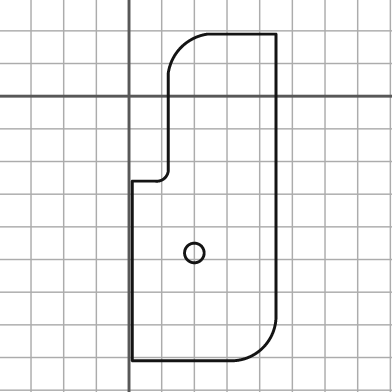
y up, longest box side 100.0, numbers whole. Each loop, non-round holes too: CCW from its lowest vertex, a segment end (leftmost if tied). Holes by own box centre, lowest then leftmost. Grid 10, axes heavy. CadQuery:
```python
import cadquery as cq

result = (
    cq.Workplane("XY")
    .moveTo(1.0, -81.0)
    .lineTo(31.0, -81.0)
    .threePointArc((41.0, -77.0), (45.0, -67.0))
    .lineTo(45.0, 19.0)
    .lineTo(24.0, 19.0)
    .threePointArc((16.0, 15.0), (12.0, 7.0))
    .lineTo(12.0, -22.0)
    .threePointArc((11.0, -25.0), (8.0, -26.0))
    .lineTo(1.0, -26.0)
    .close()
    .moveTo(20.0, -48.0)
    .circle(3.0)
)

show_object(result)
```